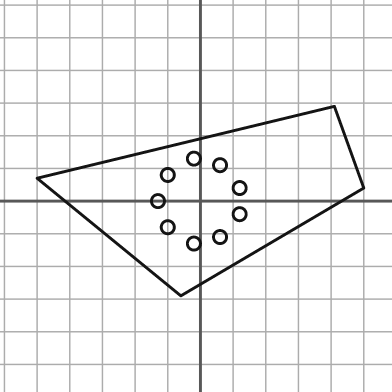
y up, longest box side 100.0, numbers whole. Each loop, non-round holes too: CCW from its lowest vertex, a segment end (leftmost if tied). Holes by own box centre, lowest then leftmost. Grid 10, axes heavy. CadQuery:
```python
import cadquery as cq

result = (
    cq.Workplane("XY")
    .moveTo(-6.0, -29.0)
    .lineTo(50.0, 4.0)
    .lineTo(41.0, 29.0)
    .lineTo(-50.0, 7.0)
    .close()
    .moveTo(-2.0, -13.0)
    .circle(2.0)
    .moveTo(6.0, -11.0)
    .circle(2.0)
    .moveTo(-10.0, -8.0)
    .circle(2.0)
    .moveTo(12.0, -4.0)
    .circle(2.0)
    .moveTo(-13.0, 0.0)
    .circle(2.0)
    .moveTo(12.0, 4.0)
    .circle(2.0)
    .moveTo(-10.0, 8.0)
    .circle(2.0)
    .moveTo(6.0, 11.0)
    .circle(2.0)
    .moveTo(-2.0, 13.0)
    .circle(2.0)
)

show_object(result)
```